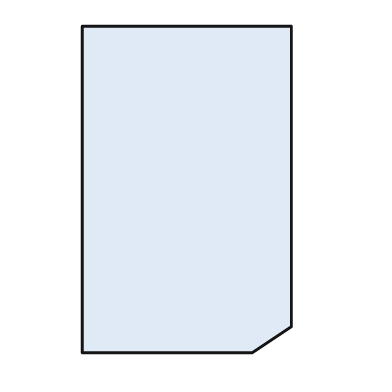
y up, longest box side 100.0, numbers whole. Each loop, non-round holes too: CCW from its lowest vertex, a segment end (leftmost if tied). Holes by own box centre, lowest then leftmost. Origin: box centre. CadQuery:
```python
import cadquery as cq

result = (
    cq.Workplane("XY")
    .moveTo(-32.0, -50.0)
    .lineTo(20.0, -50.0)
    .lineTo(32.0, -42.0)
    .lineTo(32.0, 50.0)
    .lineTo(-32.0, 50.0)
    .close()
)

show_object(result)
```